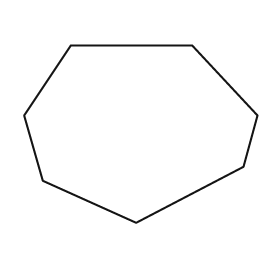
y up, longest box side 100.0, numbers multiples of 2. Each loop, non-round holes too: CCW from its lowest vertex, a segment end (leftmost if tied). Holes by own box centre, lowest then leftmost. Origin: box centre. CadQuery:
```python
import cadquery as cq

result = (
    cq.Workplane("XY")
    .moveTo(-2.0, -38.0)
    .lineTo(44.0, -14.0)
    .lineTo(50.0, 8.0)
    .lineTo(22.0, 38.0)
    .lineTo(-30.0, 38.0)
    .lineTo(-50.0, 8.0)
    .lineTo(-42.0, -20.0)
    .close()
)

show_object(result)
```